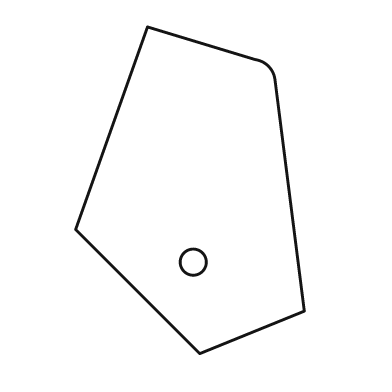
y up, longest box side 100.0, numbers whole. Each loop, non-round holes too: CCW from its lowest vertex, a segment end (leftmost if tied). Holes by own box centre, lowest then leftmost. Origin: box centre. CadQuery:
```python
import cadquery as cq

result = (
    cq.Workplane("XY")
    .moveTo(3.0, -50.0)
    .lineTo(35.0, -37.0)
    .lineTo(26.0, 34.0)
    .threePointArc((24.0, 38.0), (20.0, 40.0))
    .lineTo(-13.0, 50.0)
    .lineTo(-35.0, -12.0)
    .close()
    .moveTo(1.0, -22.0)
    .circle(4.0)
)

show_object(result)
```